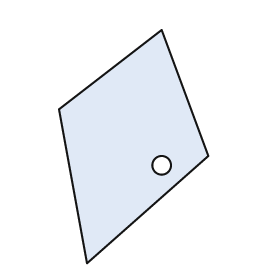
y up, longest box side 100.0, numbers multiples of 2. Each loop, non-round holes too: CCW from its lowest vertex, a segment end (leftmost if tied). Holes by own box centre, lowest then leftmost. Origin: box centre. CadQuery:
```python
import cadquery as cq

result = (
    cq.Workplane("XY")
    .moveTo(-20.0, -50.0)
    .lineTo(32.0, -4.0)
    .lineTo(12.0, 50.0)
    .lineTo(-32.0, 16.0)
    .close()
    .moveTo(12.0, -8.0)
    .circle(4.0)
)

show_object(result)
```